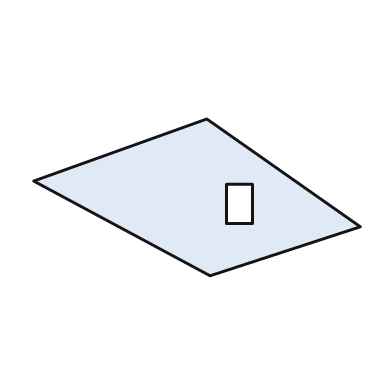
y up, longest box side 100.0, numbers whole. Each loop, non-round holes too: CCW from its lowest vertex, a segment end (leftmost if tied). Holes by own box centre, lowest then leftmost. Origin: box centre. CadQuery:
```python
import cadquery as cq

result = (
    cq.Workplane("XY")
    .moveTo(4.0, -24.0)
    .lineTo(50.0, -9.0)
    .lineTo(3.0, 24.0)
    .lineTo(-50.0, 5.0)
    .close()
    .moveTo(9.0, -8.0)
    .lineTo(17.0, -8.0)
    .lineTo(17.0, 4.0)
    .lineTo(9.0, 4.0)
    .close()
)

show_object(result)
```